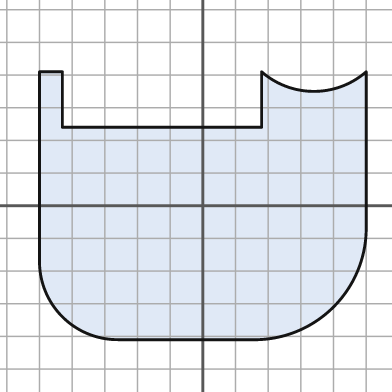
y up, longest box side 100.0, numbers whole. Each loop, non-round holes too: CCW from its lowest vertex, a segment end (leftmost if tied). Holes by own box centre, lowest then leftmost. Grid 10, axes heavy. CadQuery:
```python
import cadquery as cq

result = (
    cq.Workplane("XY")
    .moveTo(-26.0, -41.0)
    .lineTo(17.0, -41.0)
    .threePointArc((40.0, -31.0), (50.0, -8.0))
    .lineTo(50.0, 41.0)
    .threePointArc((34.0, 35.0), (18.0, 41.0))
    .lineTo(18.0, 24.0)
    .lineTo(-43.0, 24.0)
    .lineTo(-43.0, 41.0)
    .lineTo(-50.0, 41.0)
    .lineTo(-50.0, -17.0)
    .threePointArc((-43.0, -34.0), (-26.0, -41.0))
    .close()
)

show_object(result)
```